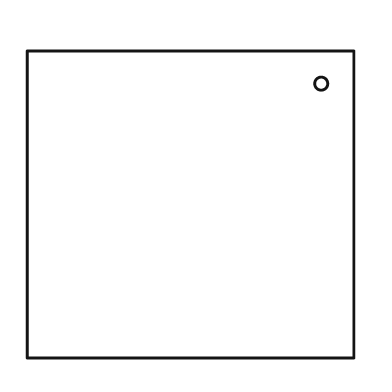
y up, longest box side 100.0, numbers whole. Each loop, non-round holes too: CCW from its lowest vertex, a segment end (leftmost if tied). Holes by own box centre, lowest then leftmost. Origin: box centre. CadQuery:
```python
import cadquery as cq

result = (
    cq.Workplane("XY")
    .moveTo(-50.0, -47.0)
    .lineTo(50.0, -47.0)
    .lineTo(50.0, 47.0)
    .lineTo(-50.0, 47.0)
    .close()
    .moveTo(40.0, 37.0)
    .circle(2.0)
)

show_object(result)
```